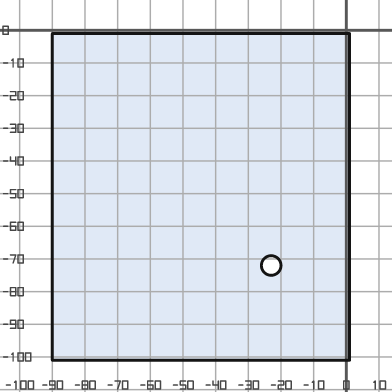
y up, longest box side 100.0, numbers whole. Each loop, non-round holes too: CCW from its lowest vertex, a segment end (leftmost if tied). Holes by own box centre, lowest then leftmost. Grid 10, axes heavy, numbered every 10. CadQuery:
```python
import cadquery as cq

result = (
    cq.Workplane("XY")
    .moveTo(-90.0, -101.0)
    .lineTo(1.0, -101.0)
    .lineTo(1.0, -1.0)
    .lineTo(-90.0, -1.0)
    .close()
    .moveTo(-23.0, -72.0)
    .circle(3.0)
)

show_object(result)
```